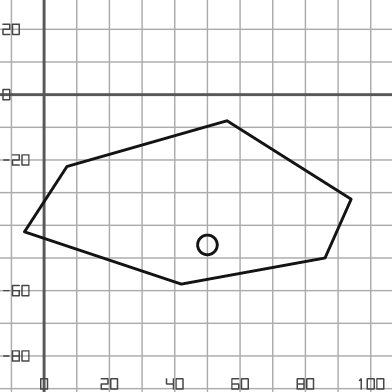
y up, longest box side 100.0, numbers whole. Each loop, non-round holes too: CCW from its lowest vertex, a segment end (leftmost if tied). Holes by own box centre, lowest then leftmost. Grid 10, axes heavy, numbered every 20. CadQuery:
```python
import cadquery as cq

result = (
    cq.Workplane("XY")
    .moveTo(42.0, -58.0)
    .lineTo(86.0, -50.0)
    .lineTo(94.0, -32.0)
    .lineTo(56.0, -8.0)
    .lineTo(7.0, -22.0)
    .lineTo(-6.0, -42.0)
    .close()
    .moveTo(50.0, -46.0)
    .circle(3.0)
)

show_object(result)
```